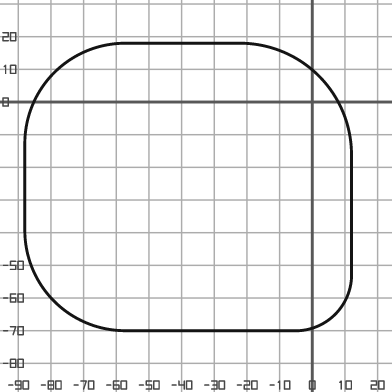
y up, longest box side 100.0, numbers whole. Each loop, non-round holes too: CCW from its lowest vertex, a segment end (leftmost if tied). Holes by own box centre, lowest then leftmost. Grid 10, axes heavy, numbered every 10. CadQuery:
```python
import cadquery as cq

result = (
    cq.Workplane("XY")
    .moveTo(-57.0, -70.0)
    .lineTo(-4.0, -70.0)
    .threePointArc((7.0, -65.0), (12.0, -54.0))
    .lineTo(12.0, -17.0)
    .threePointArc((2.0, 8.0), (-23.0, 18.0))
    .lineTo(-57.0, 18.0)
    .threePointArc((-79.0, 9.0), (-88.0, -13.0))
    .lineTo(-88.0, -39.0)
    .threePointArc((-79.0, -61.0), (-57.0, -70.0))
    .close()
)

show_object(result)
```